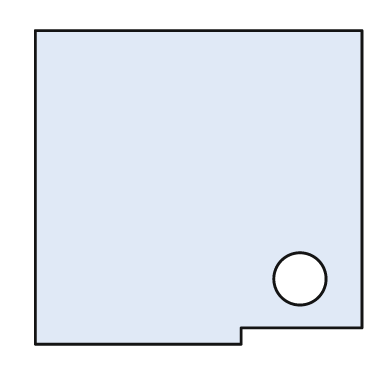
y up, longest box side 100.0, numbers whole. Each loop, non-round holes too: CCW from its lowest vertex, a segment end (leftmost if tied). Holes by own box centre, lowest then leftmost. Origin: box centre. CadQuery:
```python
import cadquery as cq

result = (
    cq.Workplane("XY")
    .moveTo(-50.0, -48.0)
    .lineTo(13.0, -48.0)
    .lineTo(13.0, -43.0)
    .lineTo(50.0, -43.0)
    .lineTo(50.0, 48.0)
    .lineTo(-50.0, 48.0)
    .close()
    .moveTo(31.0, -28.0)
    .circle(8.0)
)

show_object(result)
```